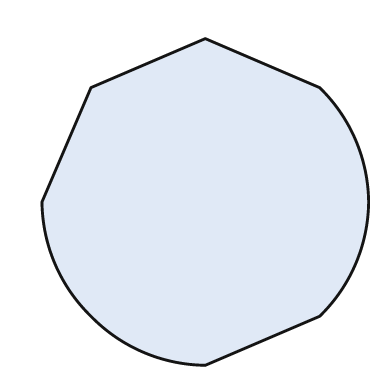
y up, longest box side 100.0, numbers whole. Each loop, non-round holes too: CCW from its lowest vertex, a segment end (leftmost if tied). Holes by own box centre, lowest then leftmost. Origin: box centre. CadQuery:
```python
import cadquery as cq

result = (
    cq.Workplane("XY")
    .moveTo(0.0, -50.0)
    .lineTo(35.0, -35.0)
    .threePointArc((46.0, -19.0), (50.0, 0.0))
    .threePointArc((46.0, 19.0), (35.0, 35.0))
    .lineTo(0.0, 50.0)
    .lineTo(-35.0, 35.0)
    .lineTo(-50.0, 0.0)
    .threePointArc((-46.0, -19.0), (-35.0, -35.0))
    .threePointArc((-19.0, -46.0), (0.0, -50.0))
    .close()
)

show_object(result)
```